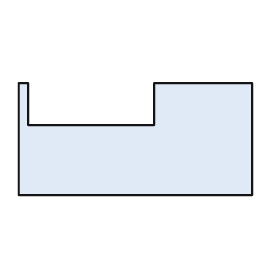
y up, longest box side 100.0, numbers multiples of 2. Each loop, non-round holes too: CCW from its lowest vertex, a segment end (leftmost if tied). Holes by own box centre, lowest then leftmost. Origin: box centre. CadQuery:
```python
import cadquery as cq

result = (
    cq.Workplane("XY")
    .moveTo(-50.0, -24.0)
    .lineTo(50.0, -24.0)
    .lineTo(50.0, 24.0)
    .lineTo(8.0, 24.0)
    .lineTo(8.0, 6.0)
    .lineTo(-46.0, 6.0)
    .lineTo(-46.0, 24.0)
    .lineTo(-50.0, 24.0)
    .close()
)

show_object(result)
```